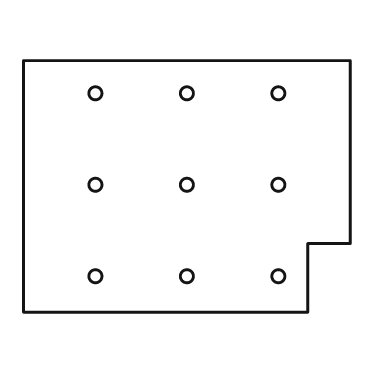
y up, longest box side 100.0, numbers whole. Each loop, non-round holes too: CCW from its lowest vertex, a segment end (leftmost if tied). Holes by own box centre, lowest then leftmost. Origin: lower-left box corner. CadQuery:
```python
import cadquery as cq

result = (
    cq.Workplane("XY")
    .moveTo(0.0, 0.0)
    .lineTo(87.0, 0.0)
    .lineTo(87.0, 21.0)
    .lineTo(100.0, 21.0)
    .lineTo(100.0, 77.0)
    .lineTo(0.0, 77.0)
    .close()
    .moveTo(22.0, 11.0)
    .circle(2.0)
    .moveTo(50.0, 11.0)
    .circle(2.0)
    .moveTo(78.0, 11.0)
    .circle(2.0)
    .moveTo(22.0, 39.0)
    .circle(2.0)
    .moveTo(50.0, 39.0)
    .circle(2.0)
    .moveTo(78.0, 39.0)
    .circle(2.0)
    .moveTo(22.0, 67.0)
    .circle(2.0)
    .moveTo(50.0, 67.0)
    .circle(2.0)
    .moveTo(78.0, 67.0)
    .circle(2.0)
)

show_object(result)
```